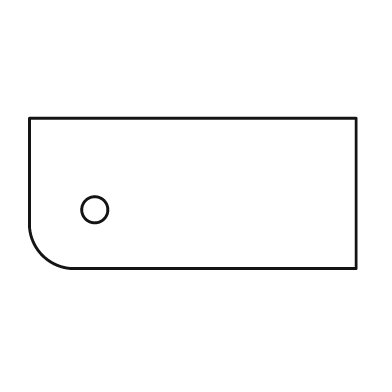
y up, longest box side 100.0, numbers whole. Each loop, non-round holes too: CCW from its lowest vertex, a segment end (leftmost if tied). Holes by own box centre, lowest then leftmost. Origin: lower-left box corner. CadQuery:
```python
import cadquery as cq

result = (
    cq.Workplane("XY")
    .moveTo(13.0, 0.0)
    .lineTo(100.0, 0.0)
    .lineTo(100.0, 46.0)
    .lineTo(0.0, 46.0)
    .lineTo(0.0, 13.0)
    .threePointArc((4.0, 4.0), (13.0, 0.0))
    .close()
    .moveTo(20.0, 18.0)
    .circle(4.0)
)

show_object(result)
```